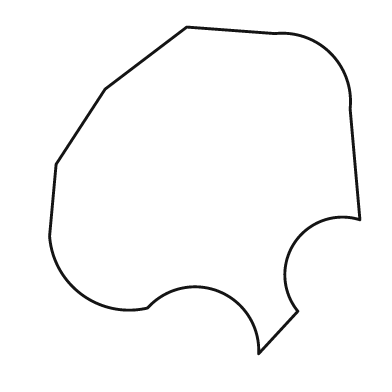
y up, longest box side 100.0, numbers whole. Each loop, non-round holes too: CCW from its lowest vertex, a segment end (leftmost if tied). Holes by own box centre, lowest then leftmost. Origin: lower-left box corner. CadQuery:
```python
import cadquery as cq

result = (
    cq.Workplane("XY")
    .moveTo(64.0, 0.0)
    .lineTo(76.0, 13.0)
    .threePointArc((75.0, 34.0), (95.0, 41.0))
    .lineTo(92.0, 75.0)
    .threePointArc((86.0, 92.0), (69.0, 98.0))
    .lineTo(42.0, 100.0)
    .lineTo(17.0, 81.0)
    .lineTo(2.0, 58.0)
    .lineTo(0.0, 36.0)
    .threePointArc((10.0, 18.0), (30.0, 14.0))
    .threePointArc((52.0, 19.0), (64.0, 0.0))
    .close()
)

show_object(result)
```